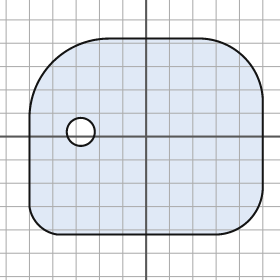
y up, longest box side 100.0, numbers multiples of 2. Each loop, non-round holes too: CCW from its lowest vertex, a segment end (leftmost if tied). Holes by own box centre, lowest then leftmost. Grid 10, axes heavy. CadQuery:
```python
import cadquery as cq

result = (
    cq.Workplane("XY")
    .moveTo(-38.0, -42.0)
    .lineTo(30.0, -42.0)
    .threePointArc((44.0, -36.0), (50.0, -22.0))
    .lineTo(50.0, 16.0)
    .threePointArc((42.0, 34.0), (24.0, 42.0))
    .lineTo(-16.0, 42.0)
    .threePointArc((-40.0, 32.0), (-50.0, 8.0))
    .lineTo(-50.0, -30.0)
    .threePointArc((-46.0, -38.0), (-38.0, -42.0))
    .close()
    .moveTo(-28.0, 2.0)
    .circle(6.0)
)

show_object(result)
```